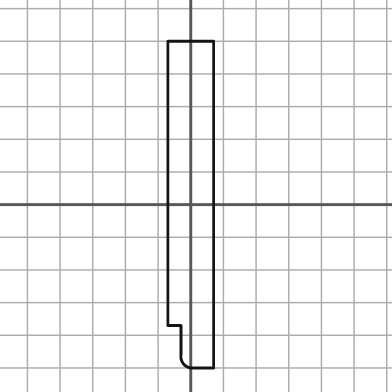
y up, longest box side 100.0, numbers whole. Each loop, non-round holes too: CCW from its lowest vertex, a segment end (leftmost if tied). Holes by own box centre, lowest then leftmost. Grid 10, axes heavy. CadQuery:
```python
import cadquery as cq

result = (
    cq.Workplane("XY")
    .moveTo(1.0, -50.0)
    .lineTo(7.0, -50.0)
    .lineTo(7.0, 50.0)
    .lineTo(-7.0, 50.0)
    .lineTo(-7.0, -37.0)
    .lineTo(-3.0, -37.0)
    .lineTo(-3.0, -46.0)
    .threePointArc((-2.0, -49.0), (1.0, -50.0))
    .close()
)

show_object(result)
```